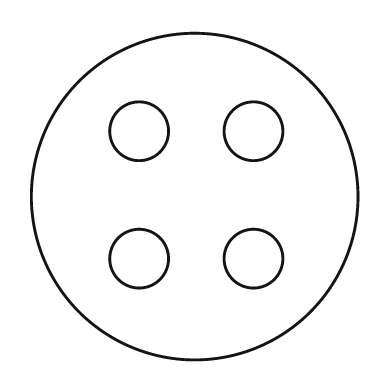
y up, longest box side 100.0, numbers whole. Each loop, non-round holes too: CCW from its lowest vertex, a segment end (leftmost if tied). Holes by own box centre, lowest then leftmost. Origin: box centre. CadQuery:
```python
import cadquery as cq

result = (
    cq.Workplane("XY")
    .moveTo(0.0, 0.0)
    .circle(50.0)
    .moveTo(-17.0, -19.0)
    .circle(9.0)
    .moveTo(18.0, -19.0)
    .circle(9.0)
    .moveTo(-17.0, 20.0)
    .circle(9.0)
    .moveTo(18.0, 20.0)
    .circle(9.0)
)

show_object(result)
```